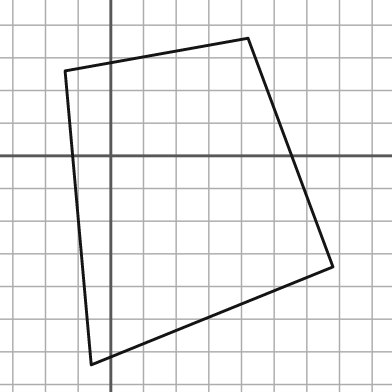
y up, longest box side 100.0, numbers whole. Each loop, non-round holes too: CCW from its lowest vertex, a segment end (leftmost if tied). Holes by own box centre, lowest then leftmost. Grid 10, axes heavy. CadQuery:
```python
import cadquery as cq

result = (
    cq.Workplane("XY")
    .moveTo(-6.0, -64.0)
    .lineTo(68.0, -34.0)
    .lineTo(42.0, 36.0)
    .lineTo(-14.0, 26.0)
    .close()
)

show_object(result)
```